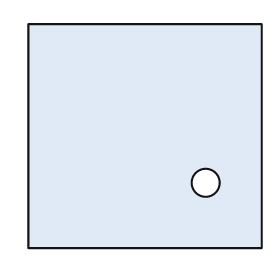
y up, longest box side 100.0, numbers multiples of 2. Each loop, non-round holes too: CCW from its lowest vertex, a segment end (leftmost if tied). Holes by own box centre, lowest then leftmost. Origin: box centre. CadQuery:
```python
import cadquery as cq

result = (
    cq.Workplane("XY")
    .moveTo(-50.0, -48.0)
    .lineTo(50.0, -48.0)
    .lineTo(50.0, 48.0)
    .lineTo(-50.0, 48.0)
    .close()
    .moveTo(26.0, -20.0)
    .circle(6.0)
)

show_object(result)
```